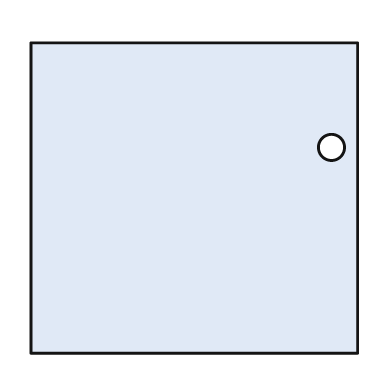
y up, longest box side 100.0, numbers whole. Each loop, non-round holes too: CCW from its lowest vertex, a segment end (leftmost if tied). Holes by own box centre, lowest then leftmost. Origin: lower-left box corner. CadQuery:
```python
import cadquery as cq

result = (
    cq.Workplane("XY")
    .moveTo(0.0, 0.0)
    .lineTo(100.0, 0.0)
    .lineTo(100.0, 95.0)
    .lineTo(0.0, 95.0)
    .close()
    .moveTo(92.0, 63.0)
    .circle(4.0)
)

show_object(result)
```